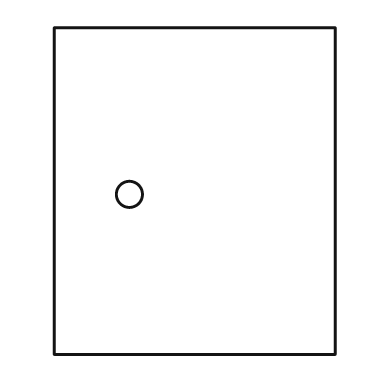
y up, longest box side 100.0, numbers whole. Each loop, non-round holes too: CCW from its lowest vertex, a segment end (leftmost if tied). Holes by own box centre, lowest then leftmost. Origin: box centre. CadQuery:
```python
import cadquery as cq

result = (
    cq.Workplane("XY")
    .moveTo(-43.0, -50.0)
    .lineTo(43.0, -50.0)
    .lineTo(43.0, 50.0)
    .lineTo(-43.0, 50.0)
    .close()
    .moveTo(-20.0, -1.0)
    .circle(4.0)
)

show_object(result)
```